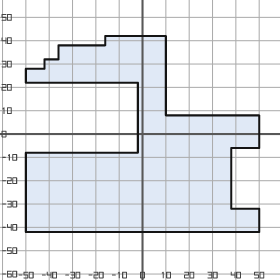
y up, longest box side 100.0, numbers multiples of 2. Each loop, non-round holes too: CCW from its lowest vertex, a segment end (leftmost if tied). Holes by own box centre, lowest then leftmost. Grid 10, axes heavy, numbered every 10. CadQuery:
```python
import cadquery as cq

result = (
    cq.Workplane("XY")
    .moveTo(-50.0, -42.0)
    .lineTo(50.0, -42.0)
    .lineTo(50.0, -32.0)
    .lineTo(38.0, -32.0)
    .lineTo(38.0, -6.0)
    .lineTo(50.0, -6.0)
    .lineTo(50.0, 8.0)
    .lineTo(10.0, 8.0)
    .lineTo(10.0, 42.0)
    .lineTo(-16.0, 42.0)
    .lineTo(-16.0, 38.0)
    .lineTo(-36.0, 38.0)
    .lineTo(-36.0, 32.0)
    .lineTo(-42.0, 32.0)
    .lineTo(-42.0, 28.0)
    .lineTo(-50.0, 28.0)
    .lineTo(-50.0, 22.0)
    .lineTo(-2.0, 22.0)
    .lineTo(-2.0, -8.0)
    .lineTo(-50.0, -8.0)
    .close()
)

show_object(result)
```